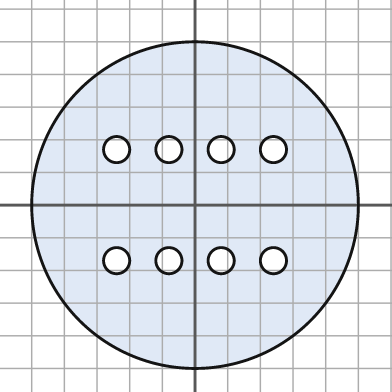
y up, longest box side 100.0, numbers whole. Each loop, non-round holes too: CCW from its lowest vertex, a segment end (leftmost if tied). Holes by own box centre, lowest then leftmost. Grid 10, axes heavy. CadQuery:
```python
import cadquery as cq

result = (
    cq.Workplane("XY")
    .moveTo(0.0, 0.0)
    .circle(50.0)
    .moveTo(-24.0, -17.0)
    .circle(4.0)
    .moveTo(-8.0, -17.0)
    .circle(4.0)
    .moveTo(8.0, -17.0)
    .circle(4.0)
    .moveTo(24.0, -17.0)
    .circle(4.0)
    .moveTo(-24.0, 17.0)
    .circle(4.0)
    .moveTo(-8.0, 17.0)
    .circle(4.0)
    .moveTo(8.0, 17.0)
    .circle(4.0)
    .moveTo(24.0, 17.0)
    .circle(4.0)
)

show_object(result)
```